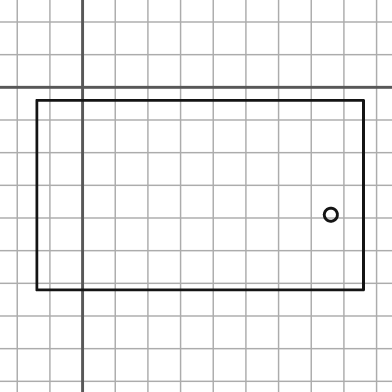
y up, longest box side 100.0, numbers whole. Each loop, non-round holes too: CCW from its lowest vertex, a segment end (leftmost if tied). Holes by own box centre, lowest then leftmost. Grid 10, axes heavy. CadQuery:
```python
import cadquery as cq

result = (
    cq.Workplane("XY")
    .moveTo(-14.0, -62.0)
    .lineTo(86.0, -62.0)
    .lineTo(86.0, -4.0)
    .lineTo(-14.0, -4.0)
    .close()
    .moveTo(76.0, -39.0)
    .circle(2.0)
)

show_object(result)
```